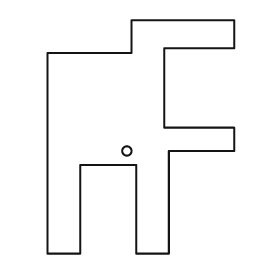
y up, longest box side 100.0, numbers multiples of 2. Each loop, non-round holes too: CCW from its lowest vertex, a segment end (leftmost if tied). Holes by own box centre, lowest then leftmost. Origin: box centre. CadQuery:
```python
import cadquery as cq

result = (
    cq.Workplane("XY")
    .moveTo(-40.0, -50.0)
    .lineTo(-26.0, -50.0)
    .lineTo(-26.0, -12.0)
    .lineTo(-2.0, -12.0)
    .lineTo(-2.0, -50.0)
    .lineTo(12.0, -50.0)
    .lineTo(12.0, -6.0)
    .lineTo(40.0, -6.0)
    .lineTo(40.0, 4.0)
    .lineTo(10.0, 4.0)
    .lineTo(10.0, 38.0)
    .lineTo(40.0, 38.0)
    .lineTo(40.0, 50.0)
    .lineTo(-4.0, 50.0)
    .lineTo(-4.0, 36.0)
    .lineTo(-40.0, 36.0)
    .close()
    .moveTo(-6.0, -6.0)
    .circle(2.0)
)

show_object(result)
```